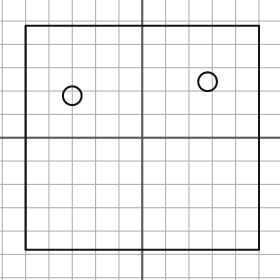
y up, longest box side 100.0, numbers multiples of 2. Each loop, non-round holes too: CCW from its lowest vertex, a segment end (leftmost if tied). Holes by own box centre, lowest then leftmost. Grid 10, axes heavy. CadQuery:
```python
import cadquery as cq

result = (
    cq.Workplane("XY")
    .moveTo(-50.0, -48.0)
    .lineTo(50.0, -48.0)
    .lineTo(50.0, 48.0)
    .lineTo(-50.0, 48.0)
    .close()
    .moveTo(-30.0, 18.0)
    .circle(4.0)
    .moveTo(28.0, 24.0)
    .circle(4.0)
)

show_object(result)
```